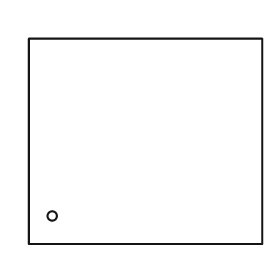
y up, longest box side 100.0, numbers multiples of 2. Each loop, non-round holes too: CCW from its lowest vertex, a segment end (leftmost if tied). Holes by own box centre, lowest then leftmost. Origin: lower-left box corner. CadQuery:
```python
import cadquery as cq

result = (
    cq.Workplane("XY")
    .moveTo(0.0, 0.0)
    .lineTo(100.0, 0.0)
    .lineTo(100.0, 88.0)
    .lineTo(0.0, 88.0)
    .close()
    .moveTo(10.0, 12.0)
    .circle(2.0)
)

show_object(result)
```